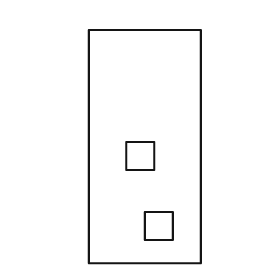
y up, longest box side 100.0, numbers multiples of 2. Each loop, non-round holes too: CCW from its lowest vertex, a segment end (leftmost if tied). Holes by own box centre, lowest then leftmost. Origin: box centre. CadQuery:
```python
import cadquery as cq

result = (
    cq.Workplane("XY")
    .moveTo(-24.0, -50.0)
    .lineTo(24.0, -50.0)
    .lineTo(24.0, 50.0)
    .lineTo(-24.0, 50.0)
    .close()
    .moveTo(0.0, -40.0)
    .lineTo(12.0, -40.0)
    .lineTo(12.0, -28.0)
    .lineTo(0.0, -28.0)
    .close()
    .moveTo(-8.0, -10.0)
    .lineTo(4.0, -10.0)
    .lineTo(4.0, 2.0)
    .lineTo(-8.0, 2.0)
    .close()
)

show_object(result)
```